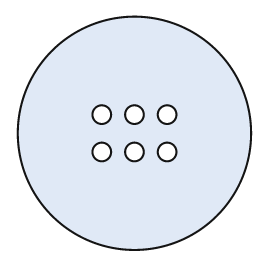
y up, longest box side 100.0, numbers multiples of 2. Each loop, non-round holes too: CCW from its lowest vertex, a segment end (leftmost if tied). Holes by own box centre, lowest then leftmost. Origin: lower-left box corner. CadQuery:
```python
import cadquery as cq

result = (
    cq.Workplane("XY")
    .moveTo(50.0, 50.0)
    .circle(50.0)
    .moveTo(36.0, 42.0)
    .circle(4.0)
    .moveTo(50.0, 42.0)
    .circle(4.0)
    .moveTo(64.0, 42.0)
    .circle(4.0)
    .moveTo(36.0, 58.0)
    .circle(4.0)
    .moveTo(50.0, 58.0)
    .circle(4.0)
    .moveTo(64.0, 58.0)
    .circle(4.0)
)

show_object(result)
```